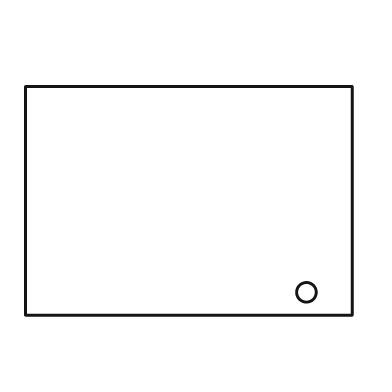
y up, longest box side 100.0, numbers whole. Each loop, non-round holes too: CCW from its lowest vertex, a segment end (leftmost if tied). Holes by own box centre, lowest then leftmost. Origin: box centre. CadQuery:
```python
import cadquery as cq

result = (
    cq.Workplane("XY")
    .moveTo(-50.0, -35.0)
    .lineTo(50.0, -35.0)
    .lineTo(50.0, 35.0)
    .lineTo(-50.0, 35.0)
    .close()
    .moveTo(36.0, -28.0)
    .circle(3.0)
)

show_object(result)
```